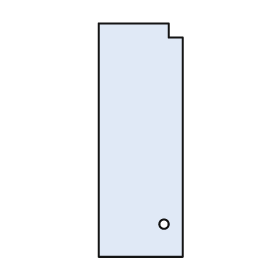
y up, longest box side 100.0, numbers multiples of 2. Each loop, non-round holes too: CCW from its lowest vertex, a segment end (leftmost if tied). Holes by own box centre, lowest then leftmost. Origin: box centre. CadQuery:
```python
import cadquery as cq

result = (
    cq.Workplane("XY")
    .moveTo(-18.0, -50.0)
    .lineTo(18.0, -50.0)
    .lineTo(18.0, 44.0)
    .lineTo(12.0, 44.0)
    .lineTo(12.0, 50.0)
    .lineTo(-18.0, 50.0)
    .close()
    .moveTo(10.0, -36.0)
    .circle(2.0)
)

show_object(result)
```